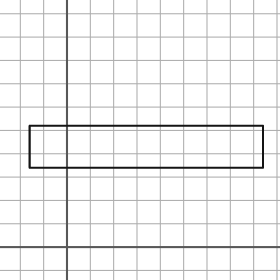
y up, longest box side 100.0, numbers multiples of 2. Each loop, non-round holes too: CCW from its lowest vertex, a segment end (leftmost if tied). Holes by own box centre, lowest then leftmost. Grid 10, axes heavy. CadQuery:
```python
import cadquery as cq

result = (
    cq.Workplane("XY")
    .moveTo(-16.0, 34.0)
    .lineTo(84.0, 34.0)
    .lineTo(84.0, 52.0)
    .lineTo(-16.0, 52.0)
    .close()
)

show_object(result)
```